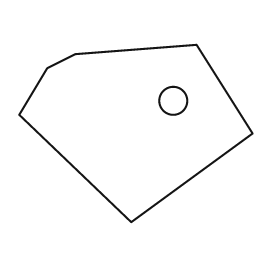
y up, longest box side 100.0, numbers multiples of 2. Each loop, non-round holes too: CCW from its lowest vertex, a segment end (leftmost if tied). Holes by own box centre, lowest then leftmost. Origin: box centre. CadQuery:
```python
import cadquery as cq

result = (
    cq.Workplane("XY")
    .moveTo(-2.0, -38.0)
    .lineTo(50.0, 0.0)
    .lineTo(26.0, 38.0)
    .lineTo(-26.0, 34.0)
    .lineTo(-38.0, 28.0)
    .lineTo(-50.0, 8.0)
    .close()
    .moveTo(16.0, 14.0)
    .circle(6.0)
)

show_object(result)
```